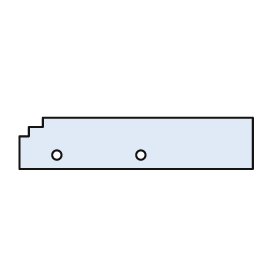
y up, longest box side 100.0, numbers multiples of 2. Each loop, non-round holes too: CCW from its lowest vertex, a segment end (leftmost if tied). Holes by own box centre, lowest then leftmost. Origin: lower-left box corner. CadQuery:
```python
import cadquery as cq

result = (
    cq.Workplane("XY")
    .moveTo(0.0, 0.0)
    .lineTo(100.0, 0.0)
    .lineTo(100.0, 22.0)
    .lineTo(10.0, 22.0)
    .lineTo(10.0, 18.0)
    .lineTo(4.0, 18.0)
    .lineTo(4.0, 14.0)
    .lineTo(0.0, 14.0)
    .close()
    .moveTo(16.0, 6.0)
    .circle(2.0)
    .moveTo(52.0, 6.0)
    .circle(2.0)
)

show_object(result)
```